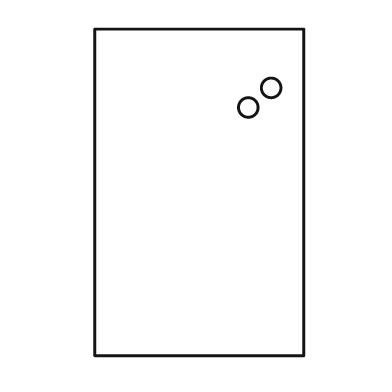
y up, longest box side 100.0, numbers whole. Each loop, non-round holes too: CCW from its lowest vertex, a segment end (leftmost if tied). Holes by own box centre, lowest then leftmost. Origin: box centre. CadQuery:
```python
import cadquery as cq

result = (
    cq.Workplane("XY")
    .moveTo(-32.0, -50.0)
    .lineTo(32.0, -50.0)
    .lineTo(32.0, 50.0)
    .lineTo(-32.0, 50.0)
    .close()
    .moveTo(15.0, 26.0)
    .circle(3.0)
    .moveTo(22.0, 32.0)
    .circle(3.0)
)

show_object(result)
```